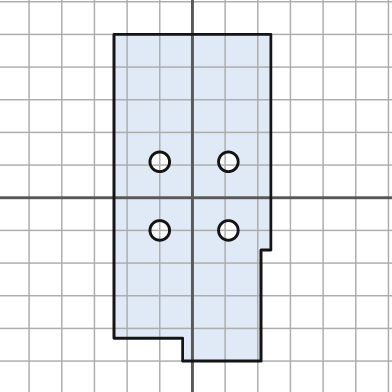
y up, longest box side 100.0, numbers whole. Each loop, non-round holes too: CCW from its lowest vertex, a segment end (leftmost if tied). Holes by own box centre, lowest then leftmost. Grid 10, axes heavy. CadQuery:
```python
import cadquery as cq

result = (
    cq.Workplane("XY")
    .moveTo(-3.0, -50.0)
    .lineTo(21.0, -50.0)
    .lineTo(21.0, -16.0)
    .lineTo(24.0, -16.0)
    .lineTo(24.0, 50.0)
    .lineTo(-24.0, 50.0)
    .lineTo(-24.0, -43.0)
    .lineTo(-3.0, -43.0)
    .close()
    .moveTo(-10.0, -10.0)
    .circle(3.0)
    .moveTo(11.0, -10.0)
    .circle(3.0)
    .moveTo(-10.0, 11.0)
    .circle(3.0)
    .moveTo(11.0, 11.0)
    .circle(3.0)
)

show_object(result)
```